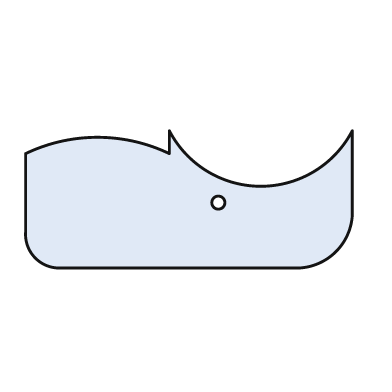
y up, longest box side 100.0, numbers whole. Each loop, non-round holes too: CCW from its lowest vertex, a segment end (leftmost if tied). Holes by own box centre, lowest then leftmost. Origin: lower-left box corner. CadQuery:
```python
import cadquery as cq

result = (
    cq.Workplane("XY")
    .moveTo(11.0, 0.0)
    .lineTo(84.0, 0.0)
    .threePointArc((95.0, 5.0), (100.0, 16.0))
    .lineTo(100.0, 42.0)
    .threePointArc((72.0, 25.0), (44.0, 42.0))
    .lineTo(44.0, 35.0)
    .threePointArc((22.0, 40.0), (0.0, 35.0))
    .lineTo(0.0, 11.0)
    .threePointArc((3.0, 3.0), (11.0, 0.0))
    .close()
    .moveTo(59.0, 20.0)
    .circle(2.0)
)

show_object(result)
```